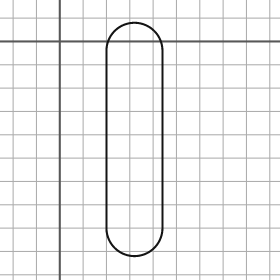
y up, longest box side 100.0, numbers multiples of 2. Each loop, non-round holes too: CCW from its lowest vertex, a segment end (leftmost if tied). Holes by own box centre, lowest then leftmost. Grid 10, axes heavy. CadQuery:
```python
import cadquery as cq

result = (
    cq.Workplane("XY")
    .moveTo(20.0, -80.0)
    .threePointArc((32.0, -92.0), (44.0, -80.0))
    .lineTo(44.0, -4.0)
    .threePointArc((32.0, 8.0), (20.0, -4.0))
    .close()
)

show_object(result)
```